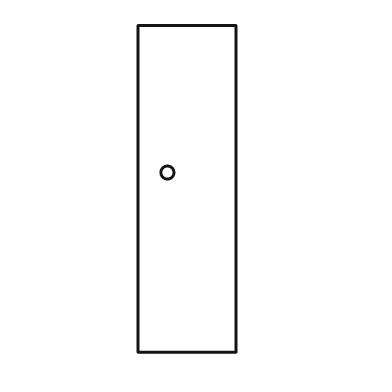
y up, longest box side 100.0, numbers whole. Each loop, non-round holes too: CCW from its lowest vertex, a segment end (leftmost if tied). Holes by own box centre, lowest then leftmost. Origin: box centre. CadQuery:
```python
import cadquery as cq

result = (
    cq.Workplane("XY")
    .moveTo(-15.0, -50.0)
    .lineTo(15.0, -50.0)
    .lineTo(15.0, 50.0)
    .lineTo(-15.0, 50.0)
    .close()
    .moveTo(-6.0, 5.0)
    .circle(2.0)
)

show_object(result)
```